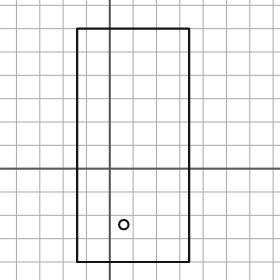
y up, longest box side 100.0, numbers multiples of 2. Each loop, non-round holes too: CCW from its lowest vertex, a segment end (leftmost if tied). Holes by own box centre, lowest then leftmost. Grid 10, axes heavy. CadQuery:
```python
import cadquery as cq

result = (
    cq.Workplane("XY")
    .moveTo(-14.0, -40.0)
    .lineTo(34.0, -40.0)
    .lineTo(34.0, 60.0)
    .lineTo(-14.0, 60.0)
    .close()
    .moveTo(6.0, -24.0)
    .circle(2.0)
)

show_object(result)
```